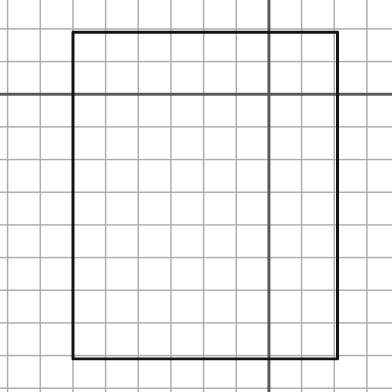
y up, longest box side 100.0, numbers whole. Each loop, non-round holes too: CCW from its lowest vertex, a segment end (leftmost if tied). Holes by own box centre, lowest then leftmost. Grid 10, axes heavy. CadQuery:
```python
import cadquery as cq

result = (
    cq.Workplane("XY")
    .moveTo(-60.0, -81.0)
    .lineTo(21.0, -81.0)
    .lineTo(21.0, 19.0)
    .lineTo(-60.0, 19.0)
    .close()
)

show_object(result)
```